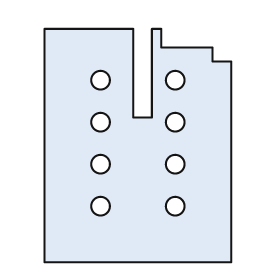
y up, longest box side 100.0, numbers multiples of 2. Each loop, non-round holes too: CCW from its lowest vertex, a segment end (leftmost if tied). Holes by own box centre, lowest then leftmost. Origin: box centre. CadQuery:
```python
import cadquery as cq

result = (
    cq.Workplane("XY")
    .moveTo(-40.0, -50.0)
    .lineTo(40.0, -50.0)
    .lineTo(40.0, 36.0)
    .lineTo(32.0, 36.0)
    .lineTo(32.0, 42.0)
    .lineTo(10.0, 42.0)
    .lineTo(10.0, 50.0)
    .lineTo(6.0, 50.0)
    .lineTo(6.0, 12.0)
    .lineTo(-2.0, 12.0)
    .lineTo(-2.0, 50.0)
    .lineTo(-40.0, 50.0)
    .close()
    .moveTo(-16.0, -26.0)
    .circle(4.0)
    .moveTo(16.0, -26.0)
    .circle(4.0)
    .moveTo(-16.0, -8.0)
    .circle(4.0)
    .moveTo(16.0, -8.0)
    .circle(4.0)
    .moveTo(-16.0, 10.0)
    .circle(4.0)
    .moveTo(16.0, 10.0)
    .circle(4.0)
    .moveTo(-16.0, 28.0)
    .circle(4.0)
    .moveTo(16.0, 28.0)
    .circle(4.0)
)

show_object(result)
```